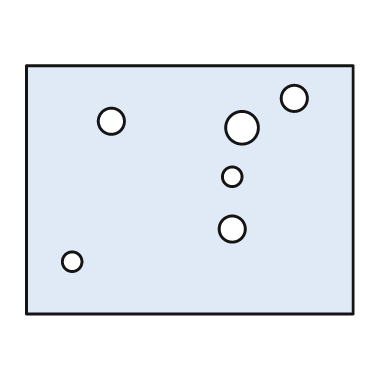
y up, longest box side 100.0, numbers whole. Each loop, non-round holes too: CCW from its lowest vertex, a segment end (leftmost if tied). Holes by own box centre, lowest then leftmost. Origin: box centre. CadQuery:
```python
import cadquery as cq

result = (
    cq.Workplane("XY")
    .moveTo(-50.0, -38.0)
    .lineTo(50.0, -38.0)
    .lineTo(50.0, 38.0)
    .lineTo(-50.0, 38.0)
    .close()
    .moveTo(-36.0, -22.0)
    .circle(3.0)
    .moveTo(13.0, -12.0)
    .circle(4.0)
    .moveTo(13.0, 4.0)
    .circle(3.0)
    .moveTo(16.0, 19.0)
    .circle(5.0)
    .moveTo(-24.0, 21.0)
    .circle(4.0)
    .moveTo(32.0, 28.0)
    .circle(4.0)
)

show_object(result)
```